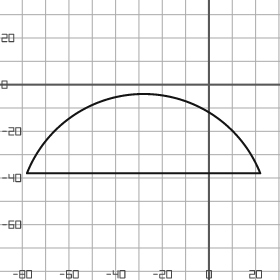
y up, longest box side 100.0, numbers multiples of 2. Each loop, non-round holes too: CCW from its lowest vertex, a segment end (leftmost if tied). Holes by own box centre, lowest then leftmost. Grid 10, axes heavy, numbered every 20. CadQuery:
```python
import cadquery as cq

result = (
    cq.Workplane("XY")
    .moveTo(-78.0, -38.0)
    .lineTo(22.0, -38.0)
    .threePointArc((-28.0, -4.0), (-78.0, -38.0))
    .close()
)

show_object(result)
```